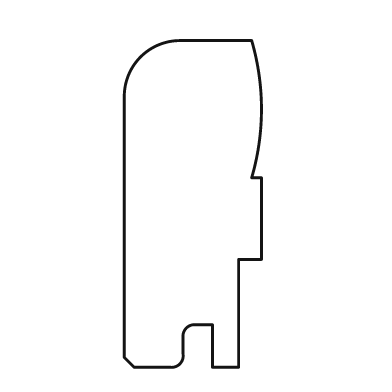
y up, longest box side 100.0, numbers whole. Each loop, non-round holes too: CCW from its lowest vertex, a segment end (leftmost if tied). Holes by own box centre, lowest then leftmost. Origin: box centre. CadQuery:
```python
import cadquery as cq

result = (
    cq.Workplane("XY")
    .moveTo(-18.0, -50.0)
    .lineTo(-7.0, -50.0)
    .threePointArc((-4.0, -49.0), (-3.0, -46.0))
    .lineTo(-3.0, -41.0)
    .threePointArc((-2.0, -38.0), (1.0, -37.0))
    .lineTo(6.0, -37.0)
    .lineTo(6.0, -50.0)
    .lineTo(14.0, -50.0)
    .lineTo(14.0, -17.0)
    .lineTo(21.0, -17.0)
    .lineTo(21.0, 8.0)
    .lineTo(18.0, 8.0)
    .threePointArc((21.0, 29.0), (18.0, 50.0))
    .lineTo(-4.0, 50.0)
    .threePointArc((-16.0, 45.0), (-21.0, 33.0))
    .lineTo(-21.0, -47.0)
    .close()
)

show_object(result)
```